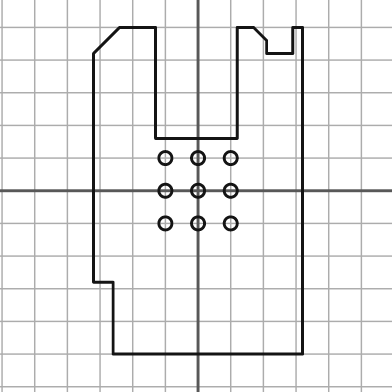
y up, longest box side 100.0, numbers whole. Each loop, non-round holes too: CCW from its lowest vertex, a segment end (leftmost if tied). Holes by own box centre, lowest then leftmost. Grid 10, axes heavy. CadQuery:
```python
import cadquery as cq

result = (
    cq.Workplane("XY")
    .moveTo(-26.0, -50.0)
    .lineTo(32.0, -50.0)
    .lineTo(32.0, 50.0)
    .lineTo(29.0, 50.0)
    .lineTo(29.0, 42.0)
    .lineTo(21.0, 42.0)
    .lineTo(21.0, 46.0)
    .lineTo(17.0, 50.0)
    .lineTo(12.0, 50.0)
    .lineTo(12.0, 16.0)
    .lineTo(-13.0, 16.0)
    .lineTo(-13.0, 50.0)
    .lineTo(-24.0, 50.0)
    .lineTo(-32.0, 42.0)
    .lineTo(-32.0, -28.0)
    .lineTo(-26.0, -28.0)
    .close()
    .moveTo(-10.0, -10.0)
    .circle(2.0)
    .moveTo(0.0, -10.0)
    .circle(2.0)
    .moveTo(10.0, -10.0)
    .circle(2.0)
    .moveTo(-10.0, 0.0)
    .circle(2.0)
    .moveTo(0.0, 0.0)
    .circle(2.0)
    .moveTo(10.0, 0.0)
    .circle(2.0)
    .moveTo(-10.0, 10.0)
    .circle(2.0)
    .moveTo(0.0, 10.0)
    .circle(2.0)
    .moveTo(10.0, 10.0)
    .circle(2.0)
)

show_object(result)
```